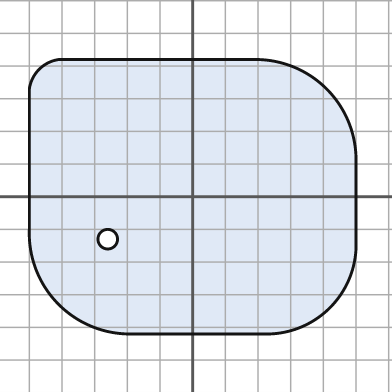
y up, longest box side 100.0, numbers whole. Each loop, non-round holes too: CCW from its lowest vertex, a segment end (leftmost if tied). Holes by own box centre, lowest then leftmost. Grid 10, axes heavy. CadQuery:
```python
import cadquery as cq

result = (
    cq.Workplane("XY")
    .moveTo(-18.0, -42.0)
    .lineTo(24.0, -42.0)
    .threePointArc((42.0, -34.0), (50.0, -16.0))
    .lineTo(50.0, 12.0)
    .threePointArc((41.0, 33.0), (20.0, 42.0))
    .lineTo(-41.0, 42.0)
    .threePointArc((-47.0, 39.0), (-50.0, 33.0))
    .lineTo(-50.0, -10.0)
    .threePointArc((-41.0, -33.0), (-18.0, -42.0))
    .close()
    .moveTo(-26.0, -13.0)
    .circle(3.0)
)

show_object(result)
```